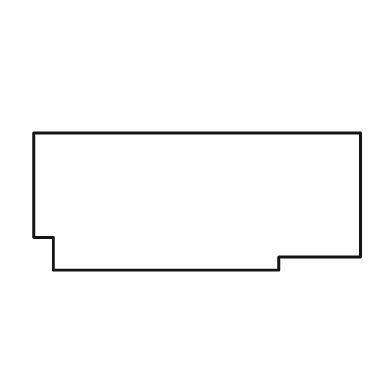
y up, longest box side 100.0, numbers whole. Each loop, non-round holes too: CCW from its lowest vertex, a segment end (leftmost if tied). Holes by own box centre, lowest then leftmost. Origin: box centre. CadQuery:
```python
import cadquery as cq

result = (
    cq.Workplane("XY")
    .moveTo(-44.0, -21.0)
    .lineTo(25.0, -21.0)
    .lineTo(25.0, -17.0)
    .lineTo(50.0, -17.0)
    .lineTo(50.0, 21.0)
    .lineTo(-50.0, 21.0)
    .lineTo(-50.0, -11.0)
    .lineTo(-44.0, -11.0)
    .close()
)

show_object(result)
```